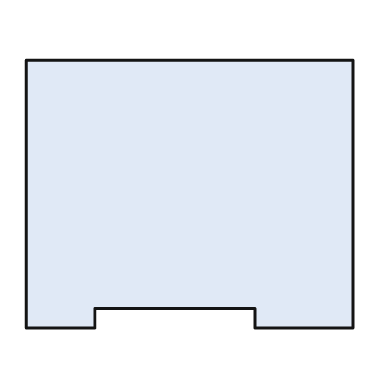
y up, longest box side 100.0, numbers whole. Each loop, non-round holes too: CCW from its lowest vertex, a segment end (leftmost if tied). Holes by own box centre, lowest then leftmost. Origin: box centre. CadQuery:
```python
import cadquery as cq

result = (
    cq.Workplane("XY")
    .moveTo(-50.0, -41.0)
    .lineTo(-29.0, -41.0)
    .lineTo(-29.0, -35.0)
    .lineTo(20.0, -35.0)
    .lineTo(20.0, -41.0)
    .lineTo(50.0, -41.0)
    .lineTo(50.0, 41.0)
    .lineTo(-50.0, 41.0)
    .close()
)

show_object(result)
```